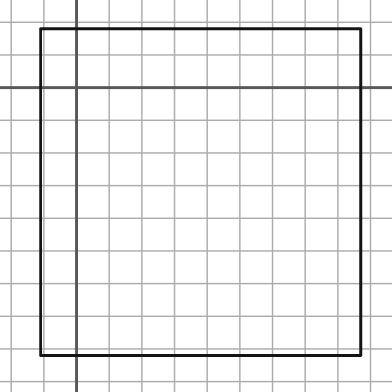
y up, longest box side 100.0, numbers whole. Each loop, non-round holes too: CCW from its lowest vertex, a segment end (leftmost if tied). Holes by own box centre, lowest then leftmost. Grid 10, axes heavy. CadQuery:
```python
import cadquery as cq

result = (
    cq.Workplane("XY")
    .moveTo(-11.0, -82.0)
    .lineTo(87.0, -82.0)
    .lineTo(87.0, 18.0)
    .lineTo(-11.0, 18.0)
    .close()
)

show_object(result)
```